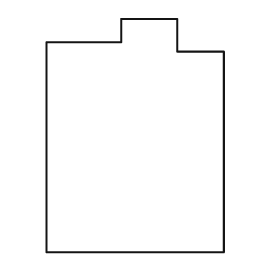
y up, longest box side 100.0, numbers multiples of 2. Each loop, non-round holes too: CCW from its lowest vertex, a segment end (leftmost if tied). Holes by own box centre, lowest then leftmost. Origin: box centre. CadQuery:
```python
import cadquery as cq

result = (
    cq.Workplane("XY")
    .moveTo(-38.0, -50.0)
    .lineTo(38.0, -50.0)
    .lineTo(38.0, 36.0)
    .lineTo(18.0, 36.0)
    .lineTo(18.0, 50.0)
    .lineTo(-6.0, 50.0)
    .lineTo(-6.0, 40.0)
    .lineTo(-38.0, 40.0)
    .close()
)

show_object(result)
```